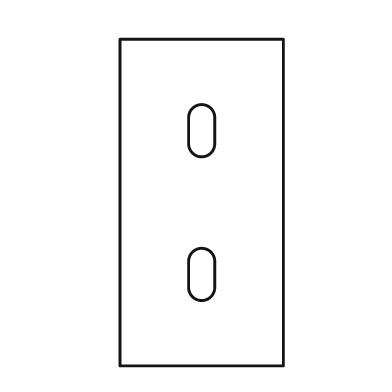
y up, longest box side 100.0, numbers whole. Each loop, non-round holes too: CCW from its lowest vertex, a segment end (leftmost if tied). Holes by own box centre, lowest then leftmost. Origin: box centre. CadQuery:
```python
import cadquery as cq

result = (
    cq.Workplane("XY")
    .moveTo(-25.0, -50.0)
    .lineTo(25.0, -50.0)
    .lineTo(25.0, 50.0)
    .lineTo(-25.0, 50.0)
    .close()
    .moveTo(-4.0, -26.0)
    .threePointArc((0.0, -30.0), (4.0, -26.0))
    .lineTo(4.0, -18.0)
    .threePointArc((0.0, -14.0), (-4.0, -18.0))
    .close()
    .moveTo(-4.0, 18.0)
    .threePointArc((0.0, 14.0), (4.0, 18.0))
    .lineTo(4.0, 26.0)
    .threePointArc((0.0, 30.0), (-4.0, 26.0))
    .close()
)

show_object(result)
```